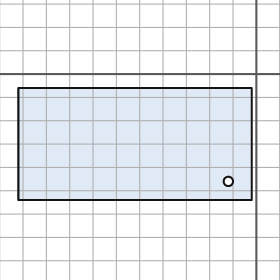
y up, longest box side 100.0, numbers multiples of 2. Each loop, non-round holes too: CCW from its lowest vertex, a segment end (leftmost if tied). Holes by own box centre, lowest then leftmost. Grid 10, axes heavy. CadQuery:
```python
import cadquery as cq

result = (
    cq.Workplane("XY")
    .moveTo(-102.0, -54.0)
    .lineTo(-2.0, -54.0)
    .lineTo(-2.0, -6.0)
    .lineTo(-102.0, -6.0)
    .close()
    .moveTo(-12.0, -46.0)
    .circle(2.0)
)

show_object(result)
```